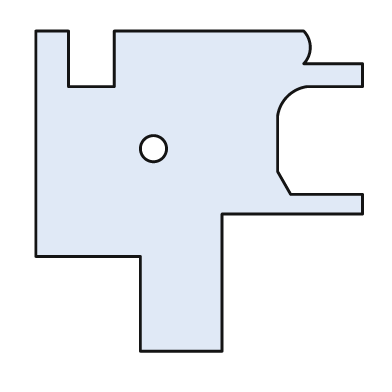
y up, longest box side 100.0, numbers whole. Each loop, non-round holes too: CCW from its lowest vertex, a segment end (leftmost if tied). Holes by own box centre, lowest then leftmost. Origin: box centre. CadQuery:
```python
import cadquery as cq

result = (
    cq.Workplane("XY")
    .moveTo(-18.0, -49.0)
    .lineTo(7.0, -49.0)
    .lineTo(7.0, -7.0)
    .lineTo(50.0, -7.0)
    .lineTo(50.0, -1.0)
    .lineTo(28.0, -1.0)
    .lineTo(24.0, 6.0)
    .lineTo(24.0, 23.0)
    .threePointArc((27.0, 29.0), (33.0, 32.0))
    .lineTo(50.0, 32.0)
    .lineTo(50.0, 39.0)
    .lineTo(32.0, 39.0)
    .threePointArc((34.0, 44.0), (32.0, 49.0))
    .lineTo(-26.0, 49.0)
    .lineTo(-26.0, 32.0)
    .lineTo(-40.0, 32.0)
    .lineTo(-40.0, 49.0)
    .lineTo(-50.0, 49.0)
    .lineTo(-50.0, -20.0)
    .lineTo(-18.0, -20.0)
    .close()
    .moveTo(-14.0, 13.0)
    .circle(4.0)
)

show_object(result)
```